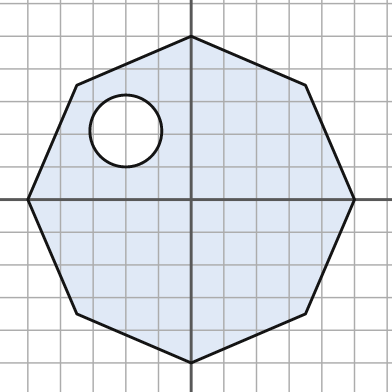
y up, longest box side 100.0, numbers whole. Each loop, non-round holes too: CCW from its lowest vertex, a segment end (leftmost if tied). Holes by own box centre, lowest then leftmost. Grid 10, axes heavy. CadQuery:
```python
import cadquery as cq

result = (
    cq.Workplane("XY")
    .moveTo(0.0, -50.0)
    .lineTo(35.0, -35.0)
    .lineTo(50.0, 0.0)
    .lineTo(35.0, 35.0)
    .lineTo(0.0, 50.0)
    .lineTo(-35.0, 35.0)
    .lineTo(-50.0, 0.0)
    .lineTo(-35.0, -35.0)
    .close()
    .moveTo(-20.0, 21.0)
    .circle(11.0)
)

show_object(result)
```